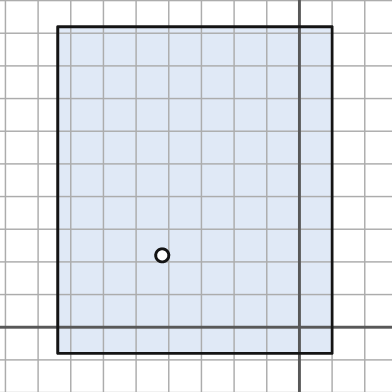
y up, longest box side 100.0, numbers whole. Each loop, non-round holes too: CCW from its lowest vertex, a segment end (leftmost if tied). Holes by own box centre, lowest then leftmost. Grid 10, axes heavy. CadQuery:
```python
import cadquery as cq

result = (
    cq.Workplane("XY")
    .moveTo(-74.0, -8.0)
    .lineTo(10.0, -8.0)
    .lineTo(10.0, 92.0)
    .lineTo(-74.0, 92.0)
    .close()
    .moveTo(-42.0, 22.0)
    .circle(2.0)
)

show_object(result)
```